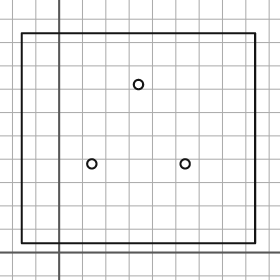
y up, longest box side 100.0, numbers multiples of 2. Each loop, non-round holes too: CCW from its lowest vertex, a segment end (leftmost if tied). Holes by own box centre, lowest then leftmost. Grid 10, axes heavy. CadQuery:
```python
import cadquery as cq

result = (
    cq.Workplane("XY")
    .moveTo(-16.0, 4.0)
    .lineTo(84.0, 4.0)
    .lineTo(84.0, 94.0)
    .lineTo(-16.0, 94.0)
    .close()
    .moveTo(14.0, 38.0)
    .circle(2.0)
    .moveTo(54.0, 38.0)
    .circle(2.0)
    .moveTo(34.0, 72.0)
    .circle(2.0)
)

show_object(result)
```